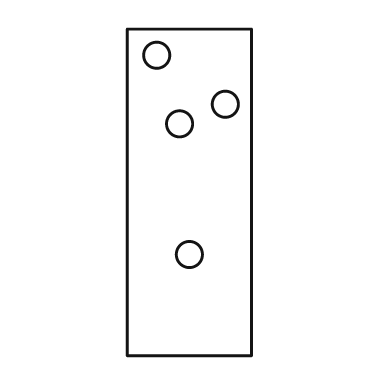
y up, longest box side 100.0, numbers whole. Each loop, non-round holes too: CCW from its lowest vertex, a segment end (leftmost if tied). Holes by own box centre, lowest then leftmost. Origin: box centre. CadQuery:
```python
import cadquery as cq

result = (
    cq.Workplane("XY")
    .moveTo(-19.0, -50.0)
    .lineTo(19.0, -50.0)
    .lineTo(19.0, 50.0)
    .lineTo(-19.0, 50.0)
    .close()
    .moveTo(0.0, -19.0)
    .circle(4.0)
    .moveTo(-3.0, 21.0)
    .circle(4.0)
    .moveTo(11.0, 27.0)
    .circle(4.0)
    .moveTo(-10.0, 42.0)
    .circle(4.0)
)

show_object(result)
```